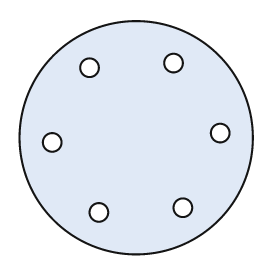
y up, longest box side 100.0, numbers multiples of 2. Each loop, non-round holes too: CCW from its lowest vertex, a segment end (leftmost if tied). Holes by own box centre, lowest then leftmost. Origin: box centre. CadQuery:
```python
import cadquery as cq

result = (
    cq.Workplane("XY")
    .moveTo(0.0, 0.0)
    .circle(50.0)
    .moveTo(-16.0, -32.0)
    .circle(4.0)
    .moveTo(20.0, -30.0)
    .circle(4.0)
    .moveTo(-36.0, -2.0)
    .circle(4.0)
    .moveTo(36.0, 2.0)
    .circle(4.0)
    .moveTo(-20.0, 30.0)
    .circle(4.0)
    .moveTo(16.0, 32.0)
    .circle(4.0)
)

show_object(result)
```